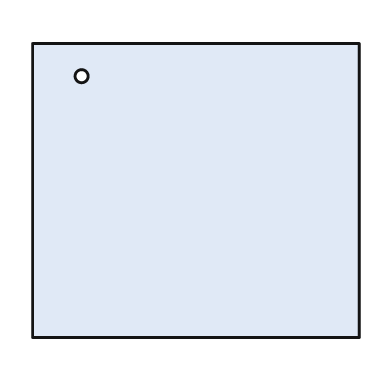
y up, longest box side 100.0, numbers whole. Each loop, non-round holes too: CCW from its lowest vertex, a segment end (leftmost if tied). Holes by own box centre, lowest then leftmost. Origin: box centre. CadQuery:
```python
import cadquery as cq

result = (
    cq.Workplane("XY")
    .moveTo(-50.0, -45.0)
    .lineTo(50.0, -45.0)
    .lineTo(50.0, 45.0)
    .lineTo(-50.0, 45.0)
    .close()
    .moveTo(-35.0, 35.0)
    .circle(2.0)
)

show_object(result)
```